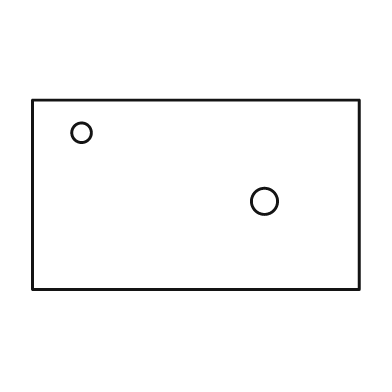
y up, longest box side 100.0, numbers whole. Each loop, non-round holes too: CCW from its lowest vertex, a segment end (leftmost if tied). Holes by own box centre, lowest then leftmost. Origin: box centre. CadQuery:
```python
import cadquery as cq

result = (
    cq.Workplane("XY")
    .moveTo(-50.0, -29.0)
    .lineTo(50.0, -29.0)
    .lineTo(50.0, 29.0)
    .lineTo(-50.0, 29.0)
    .close()
    .moveTo(21.0, -2.0)
    .circle(4.0)
    .moveTo(-35.0, 19.0)
    .circle(3.0)
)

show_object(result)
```